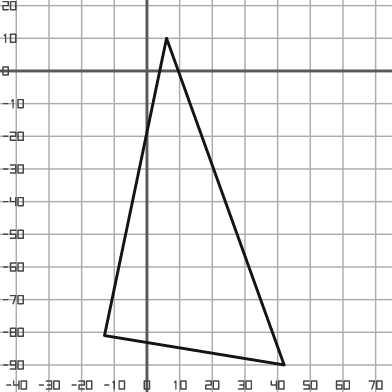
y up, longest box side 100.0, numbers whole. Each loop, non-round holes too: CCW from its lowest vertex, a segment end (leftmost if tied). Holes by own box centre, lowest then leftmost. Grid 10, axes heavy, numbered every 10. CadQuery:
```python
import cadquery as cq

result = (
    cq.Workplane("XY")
    .moveTo(42.0, -90.0)
    .lineTo(6.0, 10.0)
    .lineTo(-13.0, -81.0)
    .close()
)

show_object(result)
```